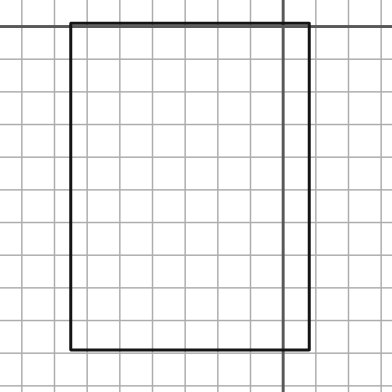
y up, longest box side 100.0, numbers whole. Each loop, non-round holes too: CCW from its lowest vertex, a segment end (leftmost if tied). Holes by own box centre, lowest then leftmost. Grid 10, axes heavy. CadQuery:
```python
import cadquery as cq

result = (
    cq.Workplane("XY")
    .moveTo(-65.0, -99.0)
    .lineTo(8.0, -99.0)
    .lineTo(8.0, 1.0)
    .lineTo(-65.0, 1.0)
    .close()
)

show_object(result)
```